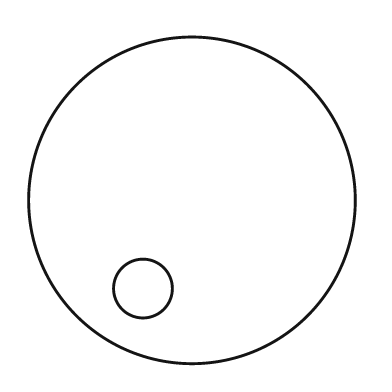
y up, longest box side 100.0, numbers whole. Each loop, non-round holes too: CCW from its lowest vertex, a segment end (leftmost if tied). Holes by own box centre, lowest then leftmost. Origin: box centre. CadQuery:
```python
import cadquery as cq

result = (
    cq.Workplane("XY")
    .moveTo(0.0, 0.0)
    .circle(50.0)
    .moveTo(-15.0, -27.0)
    .circle(9.0)
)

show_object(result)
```